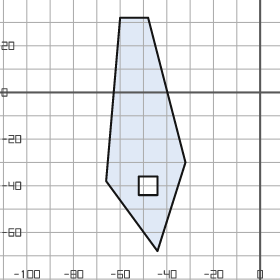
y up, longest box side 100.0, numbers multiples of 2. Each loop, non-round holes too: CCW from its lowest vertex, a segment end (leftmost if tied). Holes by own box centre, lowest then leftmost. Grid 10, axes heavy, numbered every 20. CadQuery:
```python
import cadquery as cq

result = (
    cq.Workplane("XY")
    .moveTo(-44.0, -68.0)
    .lineTo(-32.0, -30.0)
    .lineTo(-48.0, 32.0)
    .lineTo(-60.0, 32.0)
    .lineTo(-66.0, -38.0)
    .close()
    .moveTo(-52.0, -44.0)
    .lineTo(-44.0, -44.0)
    .lineTo(-44.0, -36.0)
    .lineTo(-52.0, -36.0)
    .close()
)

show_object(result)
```